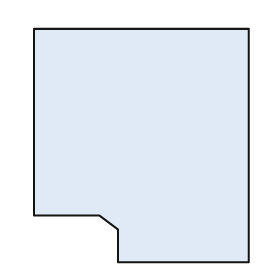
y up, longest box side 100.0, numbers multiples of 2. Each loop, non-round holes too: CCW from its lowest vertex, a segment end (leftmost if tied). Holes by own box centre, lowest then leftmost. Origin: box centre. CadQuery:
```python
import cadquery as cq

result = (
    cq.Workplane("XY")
    .moveTo(-10.0, -50.0)
    .lineTo(46.0, -50.0)
    .lineTo(46.0, 50.0)
    .lineTo(-46.0, 50.0)
    .lineTo(-46.0, -30.0)
    .lineTo(-18.0, -30.0)
    .lineTo(-10.0, -36.0)
    .close()
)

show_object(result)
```